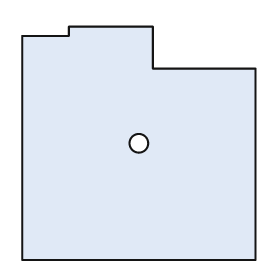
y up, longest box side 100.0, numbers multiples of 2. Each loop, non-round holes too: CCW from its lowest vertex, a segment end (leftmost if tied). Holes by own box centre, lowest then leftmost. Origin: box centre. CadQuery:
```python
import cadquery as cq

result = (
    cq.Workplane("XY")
    .moveTo(-50.0, -50.0)
    .lineTo(50.0, -50.0)
    .lineTo(50.0, 32.0)
    .lineTo(6.0, 32.0)
    .lineTo(6.0, 50.0)
    .lineTo(-30.0, 50.0)
    .lineTo(-30.0, 46.0)
    .lineTo(-50.0, 46.0)
    .close()
    .moveTo(0.0, 0.0)
    .circle(4.0)
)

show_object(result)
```